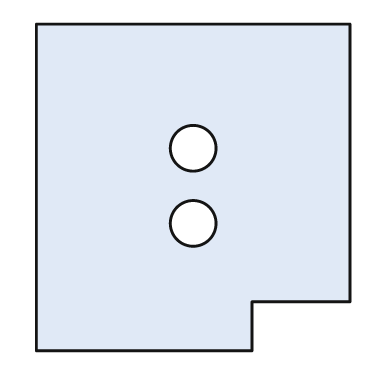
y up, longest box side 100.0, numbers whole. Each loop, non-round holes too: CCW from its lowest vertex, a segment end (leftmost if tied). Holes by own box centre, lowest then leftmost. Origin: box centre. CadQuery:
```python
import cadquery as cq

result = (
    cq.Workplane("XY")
    .moveTo(-48.0, -50.0)
    .lineTo(18.0, -50.0)
    .lineTo(18.0, -35.0)
    .lineTo(48.0, -35.0)
    .lineTo(48.0, 50.0)
    .lineTo(-48.0, 50.0)
    .close()
    .moveTo(0.0, -11.0)
    .circle(7.0)
    .moveTo(0.0, 12.0)
    .circle(7.0)
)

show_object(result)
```